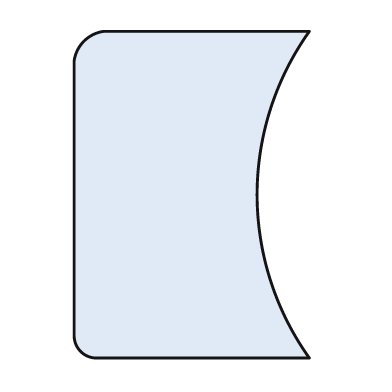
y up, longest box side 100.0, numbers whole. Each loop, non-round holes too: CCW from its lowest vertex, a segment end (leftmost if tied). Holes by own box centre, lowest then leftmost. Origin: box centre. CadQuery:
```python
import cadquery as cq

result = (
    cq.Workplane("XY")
    .moveTo(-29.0, -50.0)
    .lineTo(36.0, -50.0)
    .threePointArc((20.0, 0.0), (36.0, 50.0))
    .lineTo(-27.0, 50.0)
    .threePointArc((-33.0, 47.0), (-36.0, 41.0))
    .lineTo(-36.0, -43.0)
    .threePointArc((-34.0, -48.0), (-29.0, -50.0))
    .close()
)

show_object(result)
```